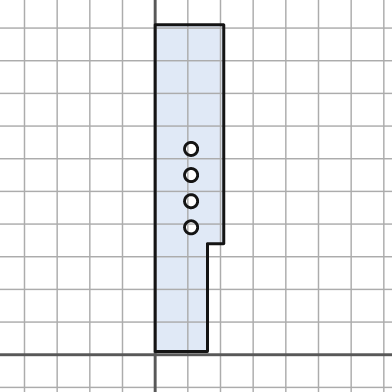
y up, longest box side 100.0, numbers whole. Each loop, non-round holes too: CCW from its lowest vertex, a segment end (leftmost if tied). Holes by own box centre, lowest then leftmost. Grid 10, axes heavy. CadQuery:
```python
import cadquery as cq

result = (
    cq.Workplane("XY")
    .moveTo(0.0, 1.0)
    .lineTo(16.0, 1.0)
    .lineTo(16.0, 34.0)
    .lineTo(21.0, 34.0)
    .lineTo(21.0, 101.0)
    .lineTo(0.0, 101.0)
    .close()
    .moveTo(11.0, 39.0)
    .circle(2.0)
    .moveTo(11.0, 47.0)
    .circle(2.0)
    .moveTo(11.0, 55.0)
    .circle(2.0)
    .moveTo(11.0, 63.0)
    .circle(2.0)
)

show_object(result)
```